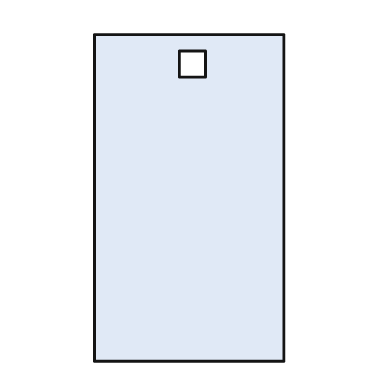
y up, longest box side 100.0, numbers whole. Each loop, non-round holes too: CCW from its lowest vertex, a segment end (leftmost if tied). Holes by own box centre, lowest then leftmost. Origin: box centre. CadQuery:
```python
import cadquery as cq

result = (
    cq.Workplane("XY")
    .moveTo(-29.0, -50.0)
    .lineTo(29.0, -50.0)
    .lineTo(29.0, 50.0)
    .lineTo(-29.0, 50.0)
    .close()
    .moveTo(-3.0, 37.0)
    .lineTo(5.0, 37.0)
    .lineTo(5.0, 45.0)
    .lineTo(-3.0, 45.0)
    .close()
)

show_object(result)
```